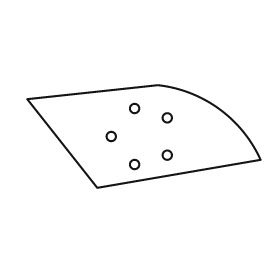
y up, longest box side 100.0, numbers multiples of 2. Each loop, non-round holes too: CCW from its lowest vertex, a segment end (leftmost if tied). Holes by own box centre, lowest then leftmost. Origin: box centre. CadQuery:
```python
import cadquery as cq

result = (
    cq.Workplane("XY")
    .moveTo(-20.0, -22.0)
    .lineTo(50.0, -10.0)
    .threePointArc((32.0, 12.0), (6.0, 22.0))
    .lineTo(-50.0, 16.0)
    .close()
    .moveTo(-4.0, -12.0)
    .circle(2.0)
    .moveTo(10.0, -8.0)
    .circle(2.0)
    .moveTo(-14.0, 0.0)
    .circle(2.0)
    .moveTo(10.0, 8.0)
    .circle(2.0)
    .moveTo(-4.0, 12.0)
    .circle(2.0)
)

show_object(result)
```